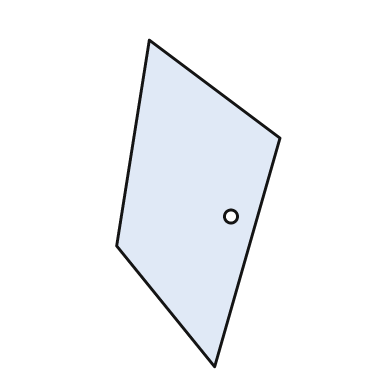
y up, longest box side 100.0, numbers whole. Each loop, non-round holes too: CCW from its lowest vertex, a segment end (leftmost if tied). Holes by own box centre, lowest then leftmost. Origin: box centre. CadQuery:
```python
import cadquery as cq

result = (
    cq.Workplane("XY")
    .moveTo(5.0, -50.0)
    .lineTo(25.0, 20.0)
    .lineTo(-15.0, 50.0)
    .lineTo(-25.0, -13.0)
    .close()
    .moveTo(10.0, -4.0)
    .circle(2.0)
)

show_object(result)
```